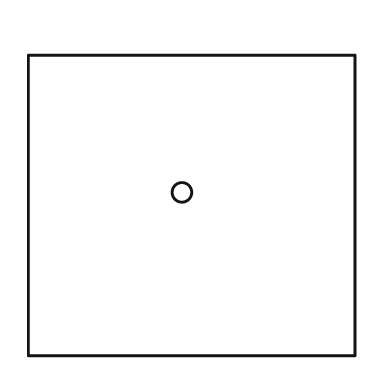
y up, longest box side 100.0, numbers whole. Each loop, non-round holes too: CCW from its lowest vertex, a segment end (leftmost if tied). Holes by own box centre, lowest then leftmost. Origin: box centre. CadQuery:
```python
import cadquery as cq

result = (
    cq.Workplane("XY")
    .moveTo(-50.0, -46.0)
    .lineTo(50.0, -46.0)
    .lineTo(50.0, 46.0)
    .lineTo(-50.0, 46.0)
    .close()
    .moveTo(-3.0, 4.0)
    .circle(3.0)
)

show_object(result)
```